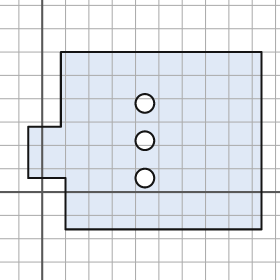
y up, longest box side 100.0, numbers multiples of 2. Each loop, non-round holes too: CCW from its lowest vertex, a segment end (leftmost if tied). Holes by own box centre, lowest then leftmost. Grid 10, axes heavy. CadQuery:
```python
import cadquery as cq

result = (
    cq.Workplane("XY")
    .moveTo(10.0, -16.0)
    .lineTo(94.0, -16.0)
    .lineTo(94.0, 60.0)
    .lineTo(8.0, 60.0)
    .lineTo(8.0, 28.0)
    .lineTo(-6.0, 28.0)
    .lineTo(-6.0, 6.0)
    .lineTo(10.0, 6.0)
    .close()
    .moveTo(44.0, 6.0)
    .circle(4.0)
    .moveTo(44.0, 22.0)
    .circle(4.0)
    .moveTo(44.0, 38.0)
    .circle(4.0)
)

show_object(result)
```